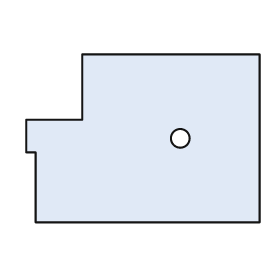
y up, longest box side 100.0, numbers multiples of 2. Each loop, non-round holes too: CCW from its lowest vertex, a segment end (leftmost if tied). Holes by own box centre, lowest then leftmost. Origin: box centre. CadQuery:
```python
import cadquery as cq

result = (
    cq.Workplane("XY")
    .moveTo(-46.0, -36.0)
    .lineTo(50.0, -36.0)
    .lineTo(50.0, 36.0)
    .lineTo(-26.0, 36.0)
    .lineTo(-26.0, 8.0)
    .lineTo(-50.0, 8.0)
    .lineTo(-50.0, -6.0)
    .lineTo(-46.0, -6.0)
    .close()
    .moveTo(16.0, 0.0)
    .circle(4.0)
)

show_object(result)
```